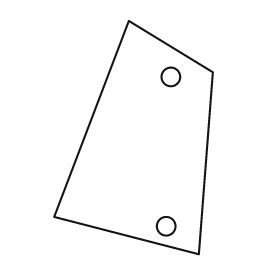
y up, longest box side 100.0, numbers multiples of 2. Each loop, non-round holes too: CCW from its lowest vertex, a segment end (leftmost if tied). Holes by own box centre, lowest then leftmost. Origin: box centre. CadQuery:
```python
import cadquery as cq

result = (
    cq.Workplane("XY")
    .moveTo(28.0, -50.0)
    .lineTo(34.0, 28.0)
    .lineTo(-2.0, 50.0)
    .lineTo(-34.0, -34.0)
    .close()
    .moveTo(14.0, -38.0)
    .circle(4.0)
    .moveTo(16.0, 26.0)
    .circle(4.0)
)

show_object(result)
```